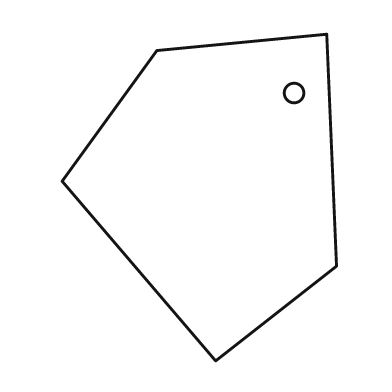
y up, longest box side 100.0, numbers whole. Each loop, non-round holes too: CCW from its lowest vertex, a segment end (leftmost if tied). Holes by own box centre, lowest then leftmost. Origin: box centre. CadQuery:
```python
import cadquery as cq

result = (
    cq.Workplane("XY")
    .moveTo(5.0, -50.0)
    .lineTo(42.0, -21.0)
    .lineTo(39.0, 50.0)
    .lineTo(-13.0, 45.0)
    .lineTo(-42.0, 5.0)
    .close()
    .moveTo(29.0, 32.0)
    .circle(3.0)
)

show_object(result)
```